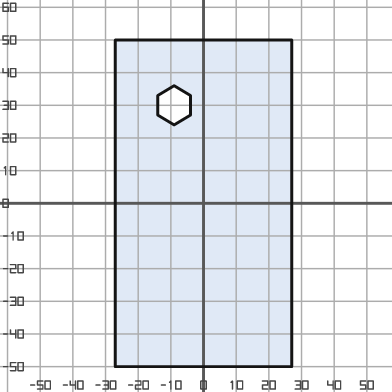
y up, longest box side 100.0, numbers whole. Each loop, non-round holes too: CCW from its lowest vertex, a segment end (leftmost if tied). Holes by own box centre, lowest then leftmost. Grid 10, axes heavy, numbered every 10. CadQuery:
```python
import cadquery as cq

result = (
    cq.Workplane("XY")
    .moveTo(-27.0, -50.0)
    .lineTo(27.0, -50.0)
    .lineTo(27.0, 50.0)
    .lineTo(-27.0, 50.0)
    .close()
    .moveTo(-9.0, 24.0)
    .lineTo(-4.0, 27.0)
    .lineTo(-4.0, 33.0)
    .lineTo(-9.0, 36.0)
    .lineTo(-14.0, 33.0)
    .lineTo(-14.0, 27.0)
    .close()
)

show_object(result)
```